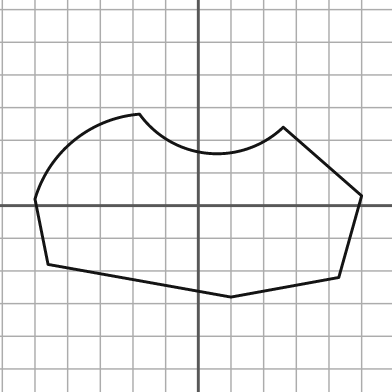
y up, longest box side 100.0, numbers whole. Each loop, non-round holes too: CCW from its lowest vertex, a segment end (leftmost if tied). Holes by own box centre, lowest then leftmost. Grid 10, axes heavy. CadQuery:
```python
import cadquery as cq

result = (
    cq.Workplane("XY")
    .moveTo(10.0, -28.0)
    .lineTo(43.0, -22.0)
    .lineTo(50.0, 3.0)
    .lineTo(26.0, 24.0)
    .threePointArc((3.0, 16.0), (-18.0, 28.0))
    .threePointArc((-38.0, 20.0), (-50.0, 2.0))
    .lineTo(-46.0, -18.0)
    .close()
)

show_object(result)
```